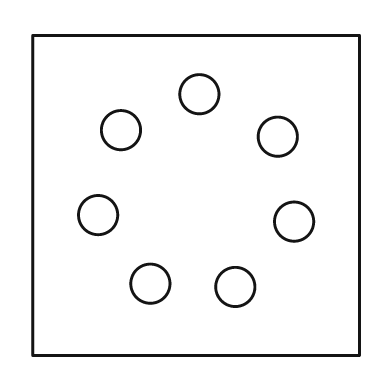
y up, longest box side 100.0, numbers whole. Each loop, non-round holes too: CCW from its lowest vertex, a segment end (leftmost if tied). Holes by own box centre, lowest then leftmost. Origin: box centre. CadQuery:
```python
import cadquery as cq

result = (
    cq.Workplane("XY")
    .moveTo(-50.0, -49.0)
    .lineTo(50.0, -49.0)
    .lineTo(50.0, 49.0)
    .lineTo(-50.0, 49.0)
    .close()
    .moveTo(12.0, -28.0)
    .circle(6.0)
    .moveTo(-14.0, -27.0)
    .circle(6.0)
    .moveTo(30.0, -8.0)
    .circle(6.0)
    .moveTo(-30.0, -6.0)
    .circle(6.0)
    .moveTo(25.0, 18.0)
    .circle(6.0)
    .moveTo(-23.0, 20.0)
    .circle(6.0)
    .moveTo(1.0, 31.0)
    .circle(6.0)
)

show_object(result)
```